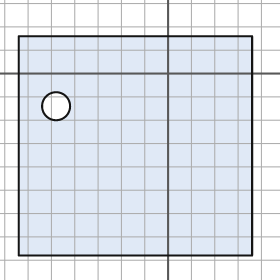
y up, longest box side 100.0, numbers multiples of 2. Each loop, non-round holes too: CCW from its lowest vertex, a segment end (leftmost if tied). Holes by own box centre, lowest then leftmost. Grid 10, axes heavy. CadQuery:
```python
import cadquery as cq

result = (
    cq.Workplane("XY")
    .moveTo(-64.0, -78.0)
    .lineTo(36.0, -78.0)
    .lineTo(36.0, 16.0)
    .lineTo(-64.0, 16.0)
    .close()
    .moveTo(-48.0, -14.0)
    .circle(6.0)
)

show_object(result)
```